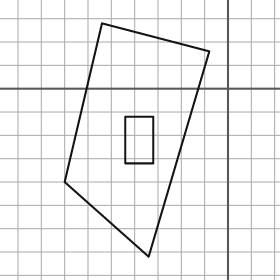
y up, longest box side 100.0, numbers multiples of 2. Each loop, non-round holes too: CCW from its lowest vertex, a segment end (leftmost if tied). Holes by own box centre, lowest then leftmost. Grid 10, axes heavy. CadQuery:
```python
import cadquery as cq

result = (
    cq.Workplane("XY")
    .moveTo(-34.0, -72.0)
    .lineTo(-8.0, 16.0)
    .lineTo(-54.0, 28.0)
    .lineTo(-70.0, -40.0)
    .close()
    .moveTo(-44.0, -32.0)
    .lineTo(-32.0, -32.0)
    .lineTo(-32.0, -12.0)
    .lineTo(-44.0, -12.0)
    .close()
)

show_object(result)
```